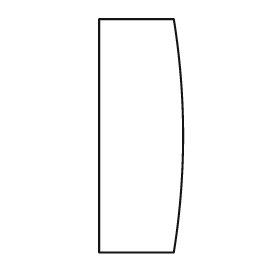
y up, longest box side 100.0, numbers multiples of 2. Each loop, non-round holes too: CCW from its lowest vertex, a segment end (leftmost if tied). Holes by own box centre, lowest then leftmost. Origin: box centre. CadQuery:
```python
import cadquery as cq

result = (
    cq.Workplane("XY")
    .moveTo(-18.0, -50.0)
    .lineTo(14.0, -50.0)
    .threePointArc((18.0, 0.0), (14.0, 50.0))
    .lineTo(-18.0, 50.0)
    .close()
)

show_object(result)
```